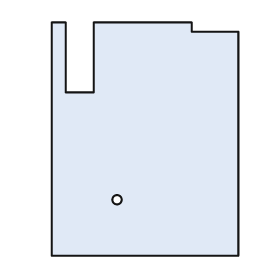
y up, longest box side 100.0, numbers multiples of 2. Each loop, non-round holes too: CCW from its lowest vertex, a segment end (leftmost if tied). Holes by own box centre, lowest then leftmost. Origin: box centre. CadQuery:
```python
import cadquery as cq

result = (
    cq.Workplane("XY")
    .moveTo(-40.0, -50.0)
    .lineTo(40.0, -50.0)
    .lineTo(40.0, 46.0)
    .lineTo(20.0, 46.0)
    .lineTo(20.0, 50.0)
    .lineTo(-22.0, 50.0)
    .lineTo(-22.0, 20.0)
    .lineTo(-34.0, 20.0)
    .lineTo(-34.0, 50.0)
    .lineTo(-40.0, 50.0)
    .close()
    .moveTo(-12.0, -26.0)
    .circle(2.0)
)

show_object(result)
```